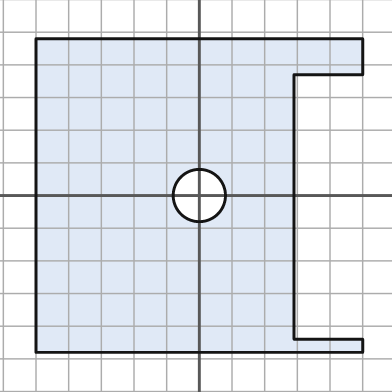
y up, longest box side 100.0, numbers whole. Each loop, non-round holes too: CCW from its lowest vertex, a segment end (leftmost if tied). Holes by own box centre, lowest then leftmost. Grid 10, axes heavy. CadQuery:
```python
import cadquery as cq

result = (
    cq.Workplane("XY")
    .moveTo(-50.0, -48.0)
    .lineTo(50.0, -48.0)
    .lineTo(50.0, -44.0)
    .lineTo(29.0, -44.0)
    .lineTo(29.0, 37.0)
    .lineTo(50.0, 37.0)
    .lineTo(50.0, 48.0)
    .lineTo(-50.0, 48.0)
    .close()
    .moveTo(0.0, 0.0)
    .circle(8.0)
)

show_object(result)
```